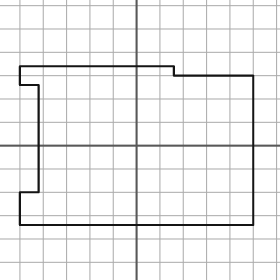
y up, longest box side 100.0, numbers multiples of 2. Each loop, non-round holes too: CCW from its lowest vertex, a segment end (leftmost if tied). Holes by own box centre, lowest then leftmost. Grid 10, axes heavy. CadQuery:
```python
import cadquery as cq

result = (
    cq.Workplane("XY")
    .moveTo(-50.0, -34.0)
    .lineTo(50.0, -34.0)
    .lineTo(50.0, 30.0)
    .lineTo(16.0, 30.0)
    .lineTo(16.0, 34.0)
    .lineTo(-50.0, 34.0)
    .lineTo(-50.0, 26.0)
    .lineTo(-42.0, 26.0)
    .lineTo(-42.0, -20.0)
    .lineTo(-50.0, -20.0)
    .close()
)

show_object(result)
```